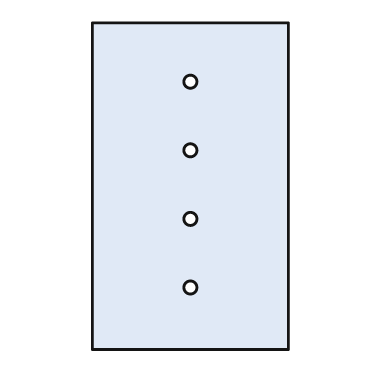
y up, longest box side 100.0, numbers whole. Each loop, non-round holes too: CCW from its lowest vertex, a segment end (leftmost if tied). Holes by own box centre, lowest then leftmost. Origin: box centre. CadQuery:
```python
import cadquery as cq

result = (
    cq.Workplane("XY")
    .moveTo(-30.0, -50.0)
    .lineTo(30.0, -50.0)
    .lineTo(30.0, 50.0)
    .lineTo(-30.0, 50.0)
    .close()
    .moveTo(0.0, -31.0)
    .circle(2.0)
    .moveTo(0.0, -10.0)
    .circle(2.0)
    .moveTo(0.0, 11.0)
    .circle(2.0)
    .moveTo(0.0, 32.0)
    .circle(2.0)
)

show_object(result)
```